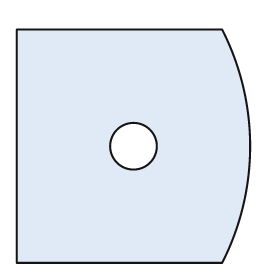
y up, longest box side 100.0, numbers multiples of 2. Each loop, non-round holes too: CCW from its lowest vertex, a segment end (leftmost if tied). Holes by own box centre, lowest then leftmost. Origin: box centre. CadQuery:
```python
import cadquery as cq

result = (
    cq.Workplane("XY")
    .moveTo(-50.0, -50.0)
    .lineTo(38.0, -50.0)
    .threePointArc((50.0, 0.0), (38.0, 50.0))
    .lineTo(-50.0, 50.0)
    .close()
    .moveTo(0.0, 0.0)
    .circle(10.0)
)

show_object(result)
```